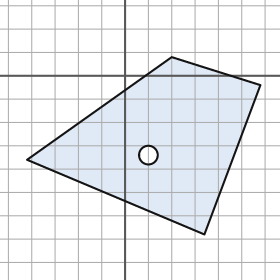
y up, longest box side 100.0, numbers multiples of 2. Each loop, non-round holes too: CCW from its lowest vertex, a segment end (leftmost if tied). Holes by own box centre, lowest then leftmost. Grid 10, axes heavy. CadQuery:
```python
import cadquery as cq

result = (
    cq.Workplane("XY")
    .moveTo(34.0, -68.0)
    .lineTo(58.0, -4.0)
    .lineTo(20.0, 8.0)
    .lineTo(-42.0, -36.0)
    .close()
    .moveTo(10.0, -34.0)
    .circle(4.0)
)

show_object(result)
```